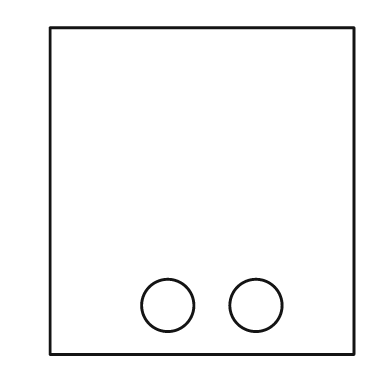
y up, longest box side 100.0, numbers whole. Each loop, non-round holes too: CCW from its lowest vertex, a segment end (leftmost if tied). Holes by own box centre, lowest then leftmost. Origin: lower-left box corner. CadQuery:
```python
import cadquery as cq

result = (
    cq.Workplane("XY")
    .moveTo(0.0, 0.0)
    .lineTo(93.0, 0.0)
    .lineTo(93.0, 100.0)
    .lineTo(0.0, 100.0)
    .close()
    .moveTo(36.0, 15.0)
    .circle(8.0)
    .moveTo(63.0, 15.0)
    .circle(8.0)
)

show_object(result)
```